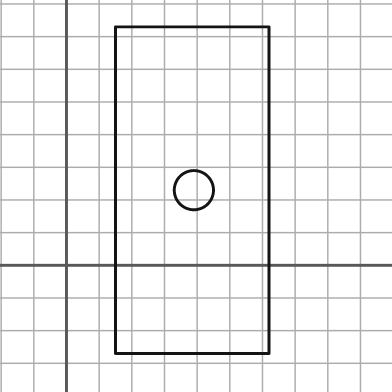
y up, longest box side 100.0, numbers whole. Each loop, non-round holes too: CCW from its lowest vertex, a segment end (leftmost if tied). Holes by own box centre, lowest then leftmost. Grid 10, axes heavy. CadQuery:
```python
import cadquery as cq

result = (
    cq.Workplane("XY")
    .moveTo(15.0, -27.0)
    .lineTo(62.0, -27.0)
    .lineTo(62.0, 73.0)
    .lineTo(15.0, 73.0)
    .close()
    .moveTo(39.0, 23.0)
    .circle(6.0)
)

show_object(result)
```